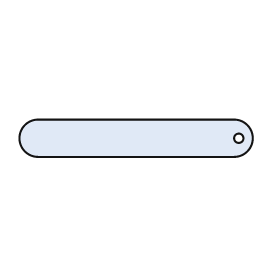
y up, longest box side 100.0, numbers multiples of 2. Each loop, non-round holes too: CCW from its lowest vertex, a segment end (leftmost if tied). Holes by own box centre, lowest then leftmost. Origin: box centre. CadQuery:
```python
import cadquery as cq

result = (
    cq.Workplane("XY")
    .moveTo(-42.0, -8.0)
    .lineTo(42.0, -8.0)
    .threePointArc((50.0, 0.0), (42.0, 8.0))
    .lineTo(-42.0, 8.0)
    .threePointArc((-50.0, 0.0), (-42.0, -8.0))
    .close()
    .moveTo(44.0, 0.0)
    .circle(2.0)
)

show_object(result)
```